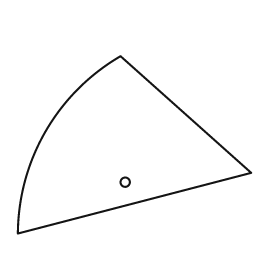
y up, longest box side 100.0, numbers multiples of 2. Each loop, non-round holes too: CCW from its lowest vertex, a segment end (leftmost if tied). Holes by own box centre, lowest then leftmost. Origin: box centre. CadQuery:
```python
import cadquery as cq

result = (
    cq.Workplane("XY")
    .moveTo(-50.0, -38.0)
    .lineTo(50.0, -12.0)
    .lineTo(-6.0, 38.0)
    .threePointArc((-38.0, 6.0), (-50.0, -38.0))
    .close()
    .moveTo(-4.0, -16.0)
    .circle(2.0)
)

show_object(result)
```